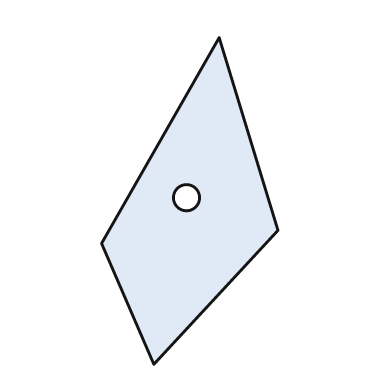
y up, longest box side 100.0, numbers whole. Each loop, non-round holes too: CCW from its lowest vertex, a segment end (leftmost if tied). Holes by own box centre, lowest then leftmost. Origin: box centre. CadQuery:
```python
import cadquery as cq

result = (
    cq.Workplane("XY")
    .moveTo(-11.0, -50.0)
    .lineTo(27.0, -9.0)
    .lineTo(9.0, 50.0)
    .lineTo(-27.0, -13.0)
    .close()
    .moveTo(-1.0, 1.0)
    .circle(4.0)
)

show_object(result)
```